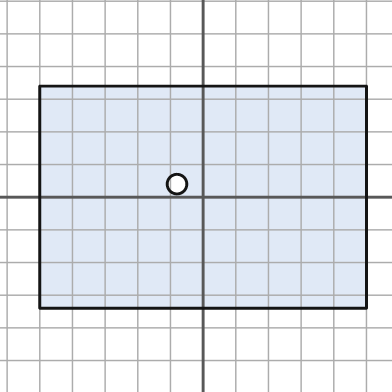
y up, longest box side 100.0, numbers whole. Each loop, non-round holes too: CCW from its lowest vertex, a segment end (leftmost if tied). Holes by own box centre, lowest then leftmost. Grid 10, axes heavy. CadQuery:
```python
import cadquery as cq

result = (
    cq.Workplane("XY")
    .moveTo(-50.0, -34.0)
    .lineTo(50.0, -34.0)
    .lineTo(50.0, 34.0)
    .lineTo(-50.0, 34.0)
    .close()
    .moveTo(-8.0, 4.0)
    .circle(3.0)
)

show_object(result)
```